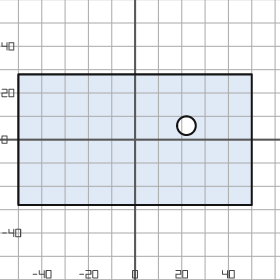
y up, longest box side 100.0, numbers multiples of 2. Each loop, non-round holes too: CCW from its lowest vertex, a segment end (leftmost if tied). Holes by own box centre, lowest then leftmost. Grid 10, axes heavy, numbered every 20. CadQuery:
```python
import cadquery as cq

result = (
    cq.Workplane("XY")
    .moveTo(-50.0, -28.0)
    .lineTo(50.0, -28.0)
    .lineTo(50.0, 28.0)
    .lineTo(-50.0, 28.0)
    .close()
    .moveTo(22.0, 6.0)
    .circle(4.0)
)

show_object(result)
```